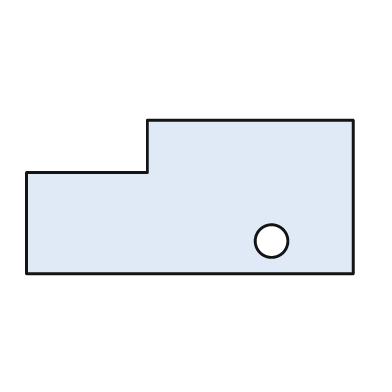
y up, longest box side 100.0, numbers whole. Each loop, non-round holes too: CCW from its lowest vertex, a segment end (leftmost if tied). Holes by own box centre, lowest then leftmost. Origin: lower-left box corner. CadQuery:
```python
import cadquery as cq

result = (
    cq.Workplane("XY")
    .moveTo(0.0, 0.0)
    .lineTo(100.0, 0.0)
    .lineTo(100.0, 47.0)
    .lineTo(37.0, 47.0)
    .lineTo(37.0, 31.0)
    .lineTo(0.0, 31.0)
    .close()
    .moveTo(75.0, 10.0)
    .circle(5.0)
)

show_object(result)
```